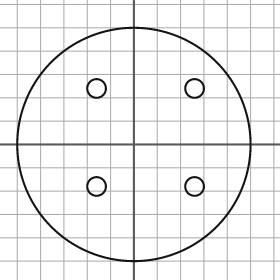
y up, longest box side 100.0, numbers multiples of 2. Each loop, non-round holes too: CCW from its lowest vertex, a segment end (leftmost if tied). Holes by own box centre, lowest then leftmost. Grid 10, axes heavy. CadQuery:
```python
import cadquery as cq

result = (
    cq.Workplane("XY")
    .moveTo(0.0, 0.0)
    .circle(50.0)
    .moveTo(-16.0, -18.0)
    .circle(4.0)
    .moveTo(26.0, -18.0)
    .circle(4.0)
    .moveTo(-16.0, 24.0)
    .circle(4.0)
    .moveTo(26.0, 24.0)
    .circle(4.0)
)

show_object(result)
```